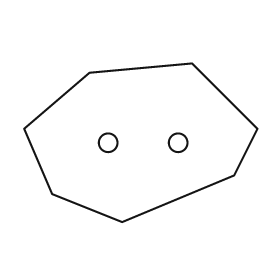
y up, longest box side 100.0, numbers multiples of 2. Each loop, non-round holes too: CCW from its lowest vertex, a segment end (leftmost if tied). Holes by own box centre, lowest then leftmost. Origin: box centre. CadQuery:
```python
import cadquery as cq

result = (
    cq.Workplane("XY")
    .moveTo(-8.0, -34.0)
    .lineTo(40.0, -14.0)
    .lineTo(50.0, 6.0)
    .lineTo(22.0, 34.0)
    .lineTo(-22.0, 30.0)
    .lineTo(-50.0, 6.0)
    .lineTo(-38.0, -22.0)
    .close()
    .moveTo(-14.0, 0.0)
    .circle(4.0)
    .moveTo(16.0, 0.0)
    .circle(4.0)
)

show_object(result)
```